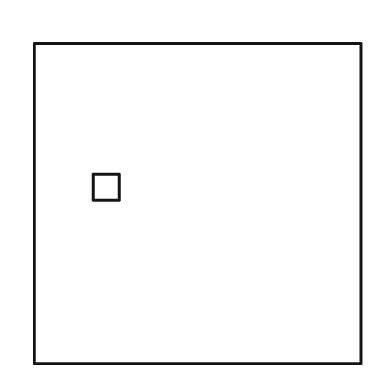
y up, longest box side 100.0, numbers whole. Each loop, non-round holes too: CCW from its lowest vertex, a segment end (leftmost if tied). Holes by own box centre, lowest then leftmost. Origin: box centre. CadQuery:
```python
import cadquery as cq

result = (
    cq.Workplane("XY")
    .moveTo(-50.0, -49.0)
    .lineTo(50.0, -49.0)
    .lineTo(50.0, 49.0)
    .lineTo(-50.0, 49.0)
    .close()
    .moveTo(-32.0, 1.0)
    .lineTo(-24.0, 1.0)
    .lineTo(-24.0, 9.0)
    .lineTo(-32.0, 9.0)
    .close()
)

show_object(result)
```